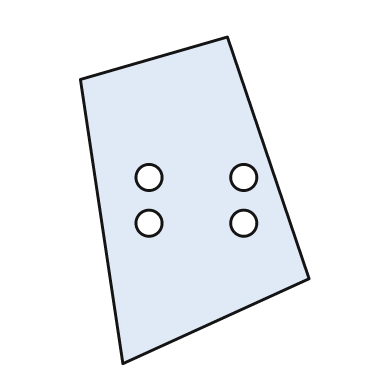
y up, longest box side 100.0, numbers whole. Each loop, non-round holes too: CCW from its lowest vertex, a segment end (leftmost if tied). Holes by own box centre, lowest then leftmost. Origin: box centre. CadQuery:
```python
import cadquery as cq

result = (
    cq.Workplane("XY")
    .moveTo(-22.0, -50.0)
    .lineTo(35.0, -24.0)
    .lineTo(10.0, 50.0)
    .lineTo(-35.0, 37.0)
    .close()
    .moveTo(-14.0, -7.0)
    .circle(4.0)
    .moveTo(15.0, -7.0)
    .circle(4.0)
    .moveTo(-14.0, 7.0)
    .circle(4.0)
    .moveTo(15.0, 7.0)
    .circle(4.0)
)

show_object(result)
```